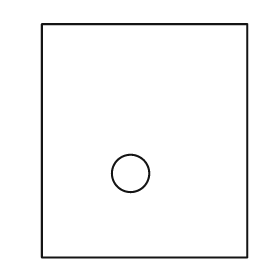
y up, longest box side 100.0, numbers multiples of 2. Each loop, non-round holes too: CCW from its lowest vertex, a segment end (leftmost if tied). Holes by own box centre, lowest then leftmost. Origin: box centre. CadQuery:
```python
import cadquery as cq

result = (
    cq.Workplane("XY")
    .moveTo(-44.0, -50.0)
    .lineTo(44.0, -50.0)
    .lineTo(44.0, 50.0)
    .lineTo(-44.0, 50.0)
    .close()
    .moveTo(-6.0, -14.0)
    .circle(8.0)
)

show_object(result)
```